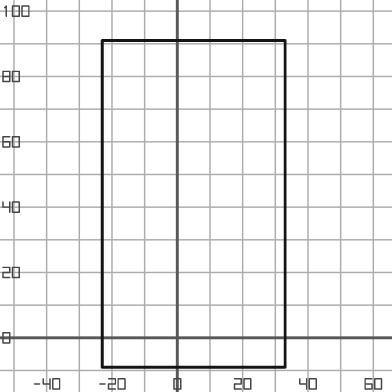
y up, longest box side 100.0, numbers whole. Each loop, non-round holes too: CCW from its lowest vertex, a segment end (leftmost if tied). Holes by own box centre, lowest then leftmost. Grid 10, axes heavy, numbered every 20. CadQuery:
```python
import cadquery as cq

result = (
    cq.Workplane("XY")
    .moveTo(-23.0, -9.0)
    .lineTo(33.0, -9.0)
    .lineTo(33.0, 91.0)
    .lineTo(-23.0, 91.0)
    .close()
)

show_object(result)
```